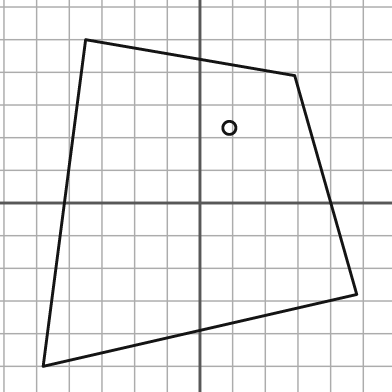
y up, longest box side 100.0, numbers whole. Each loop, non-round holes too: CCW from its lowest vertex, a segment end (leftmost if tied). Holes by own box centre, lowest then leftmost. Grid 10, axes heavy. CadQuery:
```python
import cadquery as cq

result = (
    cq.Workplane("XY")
    .moveTo(-48.0, -50.0)
    .lineTo(48.0, -28.0)
    .lineTo(29.0, 39.0)
    .lineTo(-35.0, 50.0)
    .close()
    .moveTo(9.0, 23.0)
    .circle(2.0)
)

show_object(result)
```